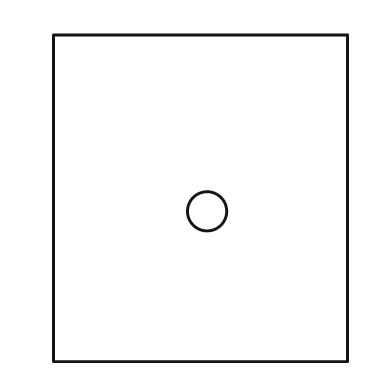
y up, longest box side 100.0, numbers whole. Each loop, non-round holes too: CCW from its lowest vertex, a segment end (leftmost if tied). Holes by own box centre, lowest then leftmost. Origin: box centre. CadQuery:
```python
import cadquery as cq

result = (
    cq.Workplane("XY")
    .moveTo(-45.0, -50.0)
    .lineTo(45.0, -50.0)
    .lineTo(45.0, 50.0)
    .lineTo(-45.0, 50.0)
    .close()
    .moveTo(2.0, -4.0)
    .circle(6.0)
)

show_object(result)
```